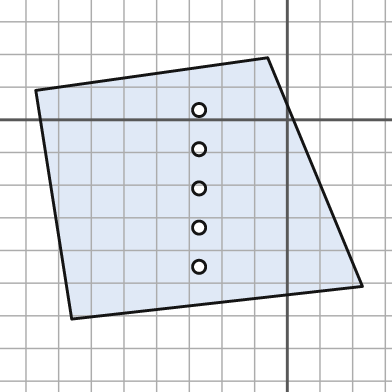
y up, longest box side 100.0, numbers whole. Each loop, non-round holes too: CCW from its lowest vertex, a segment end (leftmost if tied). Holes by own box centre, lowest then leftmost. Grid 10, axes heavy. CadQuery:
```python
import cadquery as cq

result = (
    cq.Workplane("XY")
    .moveTo(-66.0, -61.0)
    .lineTo(23.0, -51.0)
    .lineTo(-6.0, 19.0)
    .lineTo(-77.0, 9.0)
    .close()
    .moveTo(-27.0, -45.0)
    .circle(2.0)
    .moveTo(-27.0, -33.0)
    .circle(2.0)
    .moveTo(-27.0, -21.0)
    .circle(2.0)
    .moveTo(-27.0, -9.0)
    .circle(2.0)
    .moveTo(-27.0, 3.0)
    .circle(2.0)
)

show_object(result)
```